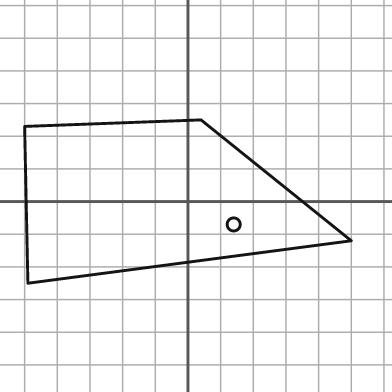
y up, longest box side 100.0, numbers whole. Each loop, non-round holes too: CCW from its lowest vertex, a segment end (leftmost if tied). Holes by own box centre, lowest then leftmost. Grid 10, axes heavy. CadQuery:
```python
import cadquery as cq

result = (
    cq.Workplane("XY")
    .moveTo(-49.0, -25.0)
    .lineTo(50.0, -12.0)
    .lineTo(4.0, 25.0)
    .lineTo(-50.0, 23.0)
    .close()
    .moveTo(14.0, -7.0)
    .circle(2.0)
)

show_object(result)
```